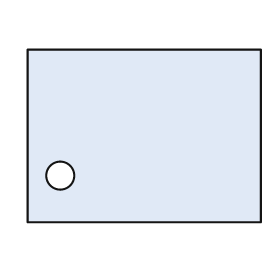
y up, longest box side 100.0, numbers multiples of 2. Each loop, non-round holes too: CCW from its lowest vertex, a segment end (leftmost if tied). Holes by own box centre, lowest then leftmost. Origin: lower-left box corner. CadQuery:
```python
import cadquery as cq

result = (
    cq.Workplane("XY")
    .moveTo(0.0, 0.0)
    .lineTo(100.0, 0.0)
    .lineTo(100.0, 74.0)
    .lineTo(0.0, 74.0)
    .close()
    .moveTo(14.0, 20.0)
    .circle(6.0)
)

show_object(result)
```